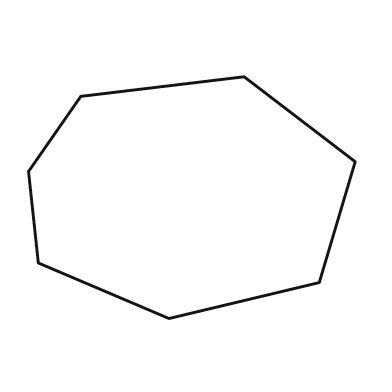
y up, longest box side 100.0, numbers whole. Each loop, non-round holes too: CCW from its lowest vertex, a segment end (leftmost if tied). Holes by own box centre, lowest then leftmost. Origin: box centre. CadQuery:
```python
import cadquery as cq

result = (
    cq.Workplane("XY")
    .moveTo(-7.0, -37.0)
    .lineTo(39.0, -26.0)
    .lineTo(50.0, 11.0)
    .lineTo(16.0, 37.0)
    .lineTo(-34.0, 31.0)
    .lineTo(-50.0, 8.0)
    .lineTo(-47.0, -20.0)
    .close()
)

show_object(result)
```